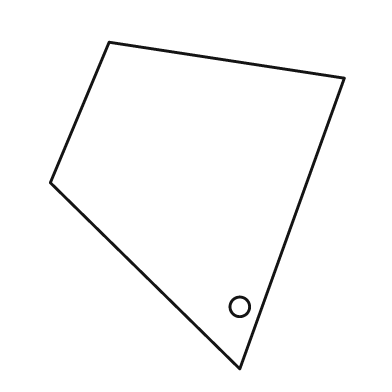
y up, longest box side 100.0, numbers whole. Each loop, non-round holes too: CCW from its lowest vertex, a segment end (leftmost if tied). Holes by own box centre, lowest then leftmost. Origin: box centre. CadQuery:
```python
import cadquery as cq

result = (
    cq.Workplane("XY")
    .moveTo(13.0, -50.0)
    .lineTo(45.0, 39.0)
    .lineTo(-27.0, 50.0)
    .lineTo(-45.0, 7.0)
    .close()
    .moveTo(13.0, -31.0)
    .circle(3.0)
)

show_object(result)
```